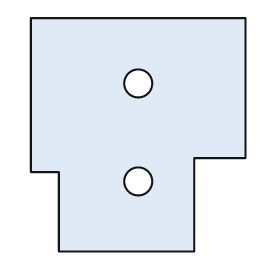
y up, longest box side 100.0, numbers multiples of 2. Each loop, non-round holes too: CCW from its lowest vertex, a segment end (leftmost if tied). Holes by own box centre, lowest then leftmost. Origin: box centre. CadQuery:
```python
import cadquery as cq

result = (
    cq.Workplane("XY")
    .moveTo(-34.0, -50.0)
    .lineTo(24.0, -50.0)
    .lineTo(24.0, -10.0)
    .lineTo(46.0, -10.0)
    .lineTo(46.0, 50.0)
    .lineTo(-46.0, 50.0)
    .lineTo(-46.0, -16.0)
    .lineTo(-34.0, -16.0)
    .close()
    .moveTo(0.0, -20.0)
    .circle(6.0)
    .moveTo(0.0, 22.0)
    .circle(6.0)
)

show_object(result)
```